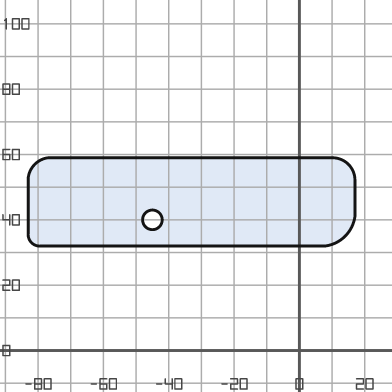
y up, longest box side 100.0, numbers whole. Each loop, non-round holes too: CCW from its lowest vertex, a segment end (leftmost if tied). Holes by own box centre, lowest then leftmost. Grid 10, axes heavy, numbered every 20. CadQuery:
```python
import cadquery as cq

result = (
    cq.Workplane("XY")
    .moveTo(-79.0, 32.0)
    .lineTo(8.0, 32.0)
    .threePointArc((14.0, 35.0), (17.0, 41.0))
    .lineTo(17.0, 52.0)
    .threePointArc((15.0, 57.0), (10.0, 59.0))
    .lineTo(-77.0, 59.0)
    .threePointArc((-81.0, 57.0), (-83.0, 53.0))
    .lineTo(-83.0, 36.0)
    .threePointArc((-82.0, 33.0), (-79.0, 32.0))
    .close()
    .moveTo(-45.0, 40.0)
    .circle(3.0)
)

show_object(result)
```